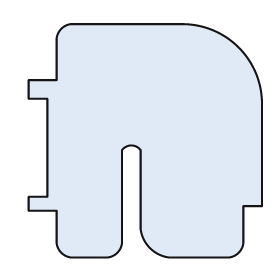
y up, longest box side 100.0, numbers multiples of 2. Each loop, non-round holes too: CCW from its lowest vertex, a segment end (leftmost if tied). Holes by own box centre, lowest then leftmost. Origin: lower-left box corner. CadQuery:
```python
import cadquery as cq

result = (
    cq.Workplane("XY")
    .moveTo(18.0, 0.0)
    .lineTo(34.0, 0.0)
    .threePointArc((38.0, 2.0), (40.0, 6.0))
    .lineTo(40.0, 46.0)
    .threePointArc((44.0, 48.0), (48.0, 46.0))
    .lineTo(48.0, 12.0)
    .threePointArc((52.0, 4.0), (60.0, 0.0))
    .lineTo(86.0, 0.0)
    .threePointArc((90.0, 2.0), (92.0, 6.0))
    .lineTo(92.0, 22.0)
    .lineTo(100.0, 22.0)
    .lineTo(100.0, 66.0)
    .threePointArc((90.0, 90.0), (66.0, 100.0))
    .lineTo(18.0, 100.0)
    .threePointArc((14.0, 98.0), (12.0, 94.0))
    .lineTo(12.0, 76.0)
    .lineTo(0.0, 76.0)
    .lineTo(0.0, 68.0)
    .lineTo(8.0, 68.0)
    .lineTo(8.0, 26.0)
    .lineTo(0.0, 26.0)
    .lineTo(0.0, 20.0)
    .lineTo(12.0, 20.0)
    .lineTo(12.0, 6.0)
    .threePointArc((14.0, 2.0), (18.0, 0.0))
    .close()
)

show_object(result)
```